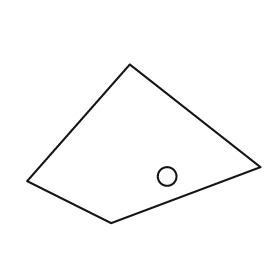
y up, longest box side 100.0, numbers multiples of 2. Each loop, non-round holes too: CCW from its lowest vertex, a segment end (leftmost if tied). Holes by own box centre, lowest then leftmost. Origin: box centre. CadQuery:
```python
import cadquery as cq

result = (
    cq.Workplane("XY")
    .moveTo(-14.0, -34.0)
    .lineTo(50.0, -10.0)
    .lineTo(-6.0, 34.0)
    .lineTo(-50.0, -16.0)
    .close()
    .moveTo(10.0, -14.0)
    .circle(4.0)
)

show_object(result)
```